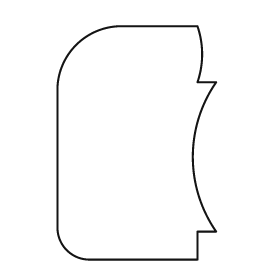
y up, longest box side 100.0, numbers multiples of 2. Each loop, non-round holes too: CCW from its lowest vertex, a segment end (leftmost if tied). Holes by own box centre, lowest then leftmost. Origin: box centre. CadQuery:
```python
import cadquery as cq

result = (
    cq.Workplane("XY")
    .moveTo(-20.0, -50.0)
    .lineTo(26.0, -50.0)
    .lineTo(26.0, -38.0)
    .lineTo(34.0, -38.0)
    .threePointArc((24.0, -6.0), (34.0, 26.0))
    .lineTo(26.0, 26.0)
    .threePointArc((28.0, 38.0), (26.0, 50.0))
    .lineTo(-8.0, 50.0)
    .threePointArc((-26.0, 42.0), (-34.0, 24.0))
    .lineTo(-34.0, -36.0)
    .threePointArc((-30.0, -46.0), (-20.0, -50.0))
    .close()
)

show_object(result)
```